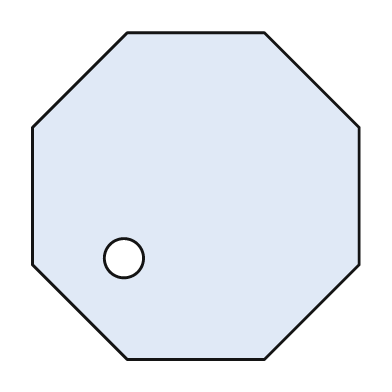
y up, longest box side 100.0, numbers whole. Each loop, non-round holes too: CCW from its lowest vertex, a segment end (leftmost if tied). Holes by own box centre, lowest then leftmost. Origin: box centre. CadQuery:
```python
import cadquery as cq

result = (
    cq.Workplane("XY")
    .moveTo(-21.0, -50.0)
    .lineTo(21.0, -50.0)
    .lineTo(50.0, -21.0)
    .lineTo(50.0, 21.0)
    .lineTo(21.0, 50.0)
    .lineTo(-21.0, 50.0)
    .lineTo(-50.0, 21.0)
    .lineTo(-50.0, -21.0)
    .close()
    .moveTo(-22.0, -19.0)
    .circle(6.0)
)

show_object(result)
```